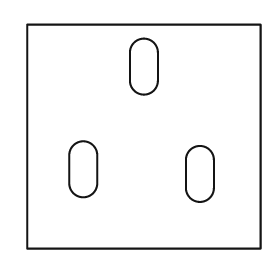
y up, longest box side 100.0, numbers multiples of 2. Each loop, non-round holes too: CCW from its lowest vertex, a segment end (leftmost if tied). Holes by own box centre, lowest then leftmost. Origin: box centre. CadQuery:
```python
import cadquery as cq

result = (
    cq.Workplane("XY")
    .moveTo(-50.0, -48.0)
    .lineTo(50.0, -48.0)
    .lineTo(50.0, 48.0)
    .lineTo(-50.0, 48.0)
    .close()
    .moveTo(18.0, -22.0)
    .threePointArc((24.0, -28.0), (30.0, -22.0))
    .lineTo(30.0, -10.0)
    .threePointArc((24.0, -4.0), (18.0, -10.0))
    .close()
    .moveTo(-32.0, -20.0)
    .threePointArc((-26.0, -26.0), (-20.0, -20.0))
    .lineTo(-20.0, -8.0)
    .threePointArc((-26.0, -2.0), (-32.0, -8.0))
    .close()
    .moveTo(-6.0, 24.0)
    .threePointArc((0.0, 18.0), (6.0, 24.0))
    .lineTo(6.0, 36.0)
    .threePointArc((0.0, 42.0), (-6.0, 36.0))
    .close()
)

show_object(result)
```